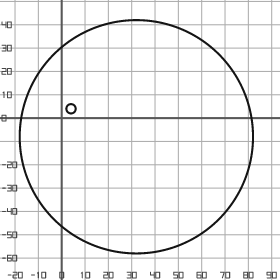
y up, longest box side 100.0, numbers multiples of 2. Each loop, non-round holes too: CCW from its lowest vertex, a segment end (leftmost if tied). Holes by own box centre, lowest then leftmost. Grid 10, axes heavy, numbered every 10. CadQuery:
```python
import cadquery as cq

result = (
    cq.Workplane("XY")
    .moveTo(32.0, -8.0)
    .circle(50.0)
    .moveTo(4.0, 4.0)
    .circle(2.0)
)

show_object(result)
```